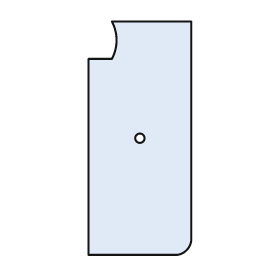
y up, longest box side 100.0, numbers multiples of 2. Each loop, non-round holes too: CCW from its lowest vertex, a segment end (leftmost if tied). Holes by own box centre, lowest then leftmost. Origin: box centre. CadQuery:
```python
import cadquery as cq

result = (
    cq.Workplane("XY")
    .moveTo(-22.0, -50.0)
    .lineTo(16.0, -50.0)
    .threePointArc((20.0, -48.0), (22.0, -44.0))
    .lineTo(22.0, 50.0)
    .lineTo(-12.0, 50.0)
    .threePointArc((-10.0, 42.0), (-12.0, 34.0))
    .lineTo(-22.0, 34.0)
    .close()
    .moveTo(0.0, 0.0)
    .circle(2.0)
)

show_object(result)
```